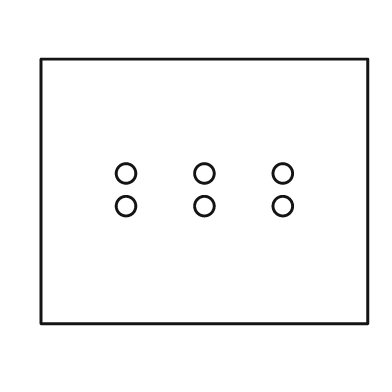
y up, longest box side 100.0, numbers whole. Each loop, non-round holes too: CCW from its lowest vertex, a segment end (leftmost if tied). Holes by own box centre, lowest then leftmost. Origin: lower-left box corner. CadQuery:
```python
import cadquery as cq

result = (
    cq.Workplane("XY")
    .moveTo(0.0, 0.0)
    .lineTo(100.0, 0.0)
    .lineTo(100.0, 81.0)
    .lineTo(0.0, 81.0)
    .close()
    .moveTo(26.0, 36.0)
    .circle(3.0)
    .moveTo(50.0, 36.0)
    .circle(3.0)
    .moveTo(74.0, 36.0)
    .circle(3.0)
    .moveTo(26.0, 46.0)
    .circle(3.0)
    .moveTo(50.0, 46.0)
    .circle(3.0)
    .moveTo(74.0, 46.0)
    .circle(3.0)
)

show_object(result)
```